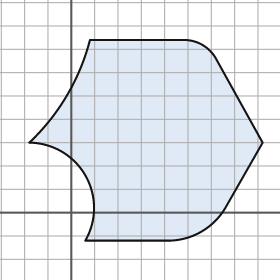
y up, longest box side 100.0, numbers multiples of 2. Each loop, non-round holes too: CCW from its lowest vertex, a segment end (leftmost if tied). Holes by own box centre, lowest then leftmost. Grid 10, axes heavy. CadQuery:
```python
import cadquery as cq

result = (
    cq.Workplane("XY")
    .moveTo(6.0, -12.0)
    .lineTo(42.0, -12.0)
    .threePointArc((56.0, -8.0), (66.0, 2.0))
    .lineTo(82.0, 30.0)
    .lineTo(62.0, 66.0)
    .threePointArc((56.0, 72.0), (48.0, 74.0))
    .lineTo(8.0, 74.0)
    .threePointArc((-2.0, 50.0), (-18.0, 30.0))
    .threePointArc((6.0, 16.0), (6.0, -12.0))
    .close()
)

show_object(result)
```